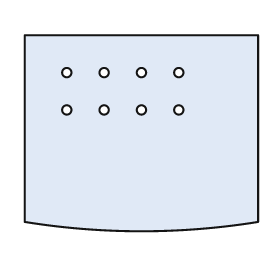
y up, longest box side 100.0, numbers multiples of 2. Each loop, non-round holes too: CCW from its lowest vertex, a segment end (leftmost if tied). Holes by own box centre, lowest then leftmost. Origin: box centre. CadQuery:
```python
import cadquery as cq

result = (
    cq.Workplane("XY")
    .moveTo(-50.0, -38.0)
    .threePointArc((0.0, -42.0), (50.0, -38.0))
    .lineTo(50.0, 42.0)
    .lineTo(-50.0, 42.0)
    .close()
    .moveTo(-32.0, 10.0)
    .circle(2.0)
    .moveTo(-16.0, 10.0)
    .circle(2.0)
    .moveTo(0.0, 10.0)
    .circle(2.0)
    .moveTo(16.0, 10.0)
    .circle(2.0)
    .moveTo(-32.0, 26.0)
    .circle(2.0)
    .moveTo(-16.0, 26.0)
    .circle(2.0)
    .moveTo(0.0, 26.0)
    .circle(2.0)
    .moveTo(16.0, 26.0)
    .circle(2.0)
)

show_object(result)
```